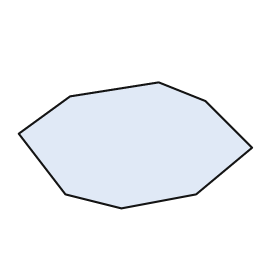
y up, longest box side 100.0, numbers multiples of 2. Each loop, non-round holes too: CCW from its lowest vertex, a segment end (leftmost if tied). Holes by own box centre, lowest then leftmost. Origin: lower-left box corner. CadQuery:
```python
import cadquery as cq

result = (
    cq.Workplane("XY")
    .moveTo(44.0, 0.0)
    .lineTo(76.0, 6.0)
    .lineTo(100.0, 26.0)
    .lineTo(80.0, 46.0)
    .lineTo(60.0, 54.0)
    .lineTo(22.0, 48.0)
    .lineTo(0.0, 32.0)
    .lineTo(20.0, 6.0)
    .close()
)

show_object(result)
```